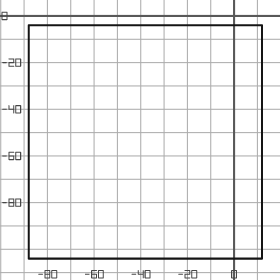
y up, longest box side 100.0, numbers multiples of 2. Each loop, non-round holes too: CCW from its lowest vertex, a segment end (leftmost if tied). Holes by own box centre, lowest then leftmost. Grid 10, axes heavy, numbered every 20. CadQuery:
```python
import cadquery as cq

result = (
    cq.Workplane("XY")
    .moveTo(-88.0, -104.0)
    .lineTo(12.0, -104.0)
    .lineTo(12.0, -4.0)
    .lineTo(-88.0, -4.0)
    .close()
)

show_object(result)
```